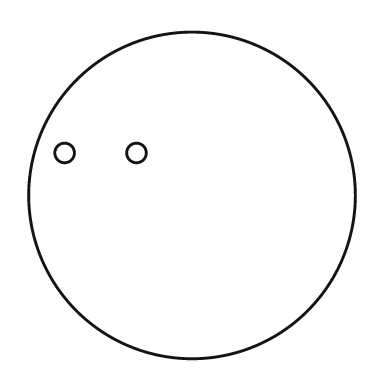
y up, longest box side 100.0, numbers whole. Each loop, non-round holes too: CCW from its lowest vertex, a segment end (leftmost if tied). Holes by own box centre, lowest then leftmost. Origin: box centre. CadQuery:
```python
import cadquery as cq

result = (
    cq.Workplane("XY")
    .moveTo(0.0, 0.0)
    .circle(50.0)
    .moveTo(-39.0, 13.0)
    .circle(3.0)
    .moveTo(-17.0, 13.0)
    .circle(3.0)
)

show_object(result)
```